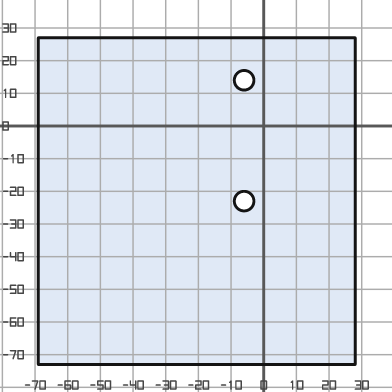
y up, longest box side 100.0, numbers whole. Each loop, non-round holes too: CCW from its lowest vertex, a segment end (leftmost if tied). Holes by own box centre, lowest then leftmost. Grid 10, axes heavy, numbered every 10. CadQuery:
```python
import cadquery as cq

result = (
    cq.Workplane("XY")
    .moveTo(-69.0, -73.0)
    .lineTo(28.0, -73.0)
    .lineTo(28.0, 27.0)
    .lineTo(-69.0, 27.0)
    .close()
    .moveTo(-6.0, -23.0)
    .circle(3.0)
    .moveTo(-6.0, 14.0)
    .circle(3.0)
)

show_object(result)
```